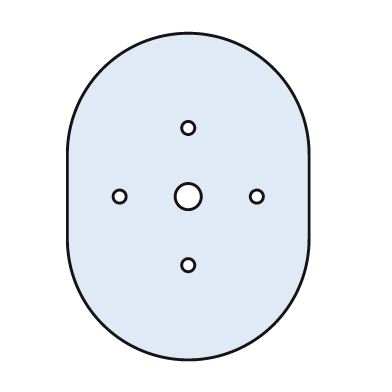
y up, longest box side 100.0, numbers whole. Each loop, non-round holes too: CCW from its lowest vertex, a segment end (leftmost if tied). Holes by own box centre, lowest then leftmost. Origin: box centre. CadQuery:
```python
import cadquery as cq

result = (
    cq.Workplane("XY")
    .moveTo(-37.0, -13.0)
    .threePointArc((0.0, -50.0), (37.0, -13.0))
    .lineTo(37.0, 13.0)
    .threePointArc((0.0, 50.0), (-37.0, 13.0))
    .close()
    .moveTo(0.0, -21.0)
    .circle(2.0)
    .moveTo(-21.0, 0.0)
    .circle(2.0)
    .moveTo(0.0, 0.0)
    .circle(4.0)
    .moveTo(21.0, 0.0)
    .circle(2.0)
    .moveTo(0.0, 21.0)
    .circle(2.0)
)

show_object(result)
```